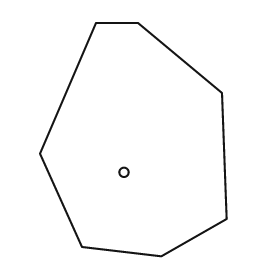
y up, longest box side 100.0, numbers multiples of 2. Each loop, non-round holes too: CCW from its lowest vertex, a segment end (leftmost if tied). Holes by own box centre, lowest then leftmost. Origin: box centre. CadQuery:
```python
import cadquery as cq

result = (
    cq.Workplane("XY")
    .moveTo(12.0, -50.0)
    .lineTo(40.0, -34.0)
    .lineTo(38.0, 20.0)
    .lineTo(2.0, 50.0)
    .lineTo(-16.0, 50.0)
    .lineTo(-40.0, -6.0)
    .lineTo(-22.0, -46.0)
    .close()
    .moveTo(-4.0, -14.0)
    .circle(2.0)
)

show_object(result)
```